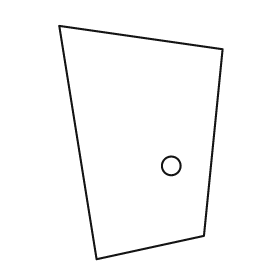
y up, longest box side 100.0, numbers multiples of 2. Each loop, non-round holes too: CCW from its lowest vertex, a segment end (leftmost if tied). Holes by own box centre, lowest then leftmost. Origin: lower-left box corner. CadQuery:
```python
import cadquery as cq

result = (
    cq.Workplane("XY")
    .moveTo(16.0, 0.0)
    .lineTo(62.0, 10.0)
    .lineTo(70.0, 90.0)
    .lineTo(0.0, 100.0)
    .close()
    .moveTo(48.0, 40.0)
    .circle(4.0)
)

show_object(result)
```